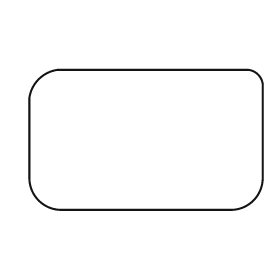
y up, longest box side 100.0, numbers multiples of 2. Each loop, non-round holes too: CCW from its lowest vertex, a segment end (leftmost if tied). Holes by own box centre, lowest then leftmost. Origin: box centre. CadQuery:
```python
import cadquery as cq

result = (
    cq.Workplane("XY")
    .moveTo(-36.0, -30.0)
    .lineTo(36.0, -30.0)
    .threePointArc((46.0, -26.0), (50.0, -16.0))
    .lineTo(50.0, 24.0)
    .threePointArc((48.0, 28.0), (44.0, 30.0))
    .lineTo(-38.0, 30.0)
    .threePointArc((-46.0, 26.0), (-50.0, 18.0))
    .lineTo(-50.0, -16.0)
    .threePointArc((-46.0, -26.0), (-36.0, -30.0))
    .close()
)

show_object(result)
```